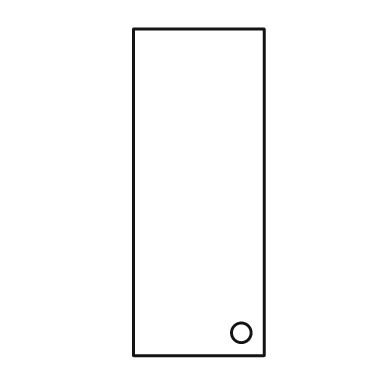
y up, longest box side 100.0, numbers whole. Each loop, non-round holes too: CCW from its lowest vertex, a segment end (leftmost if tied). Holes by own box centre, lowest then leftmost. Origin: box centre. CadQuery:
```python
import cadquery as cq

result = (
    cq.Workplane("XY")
    .moveTo(-20.0, -50.0)
    .lineTo(20.0, -50.0)
    .lineTo(20.0, 50.0)
    .lineTo(-20.0, 50.0)
    .close()
    .moveTo(13.0, -43.0)
    .circle(3.0)
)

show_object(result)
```